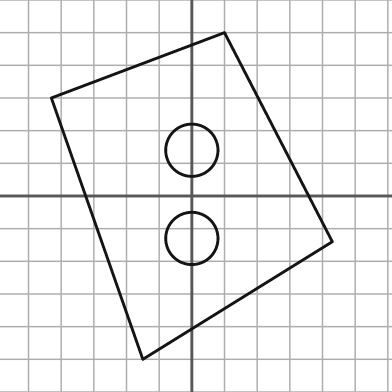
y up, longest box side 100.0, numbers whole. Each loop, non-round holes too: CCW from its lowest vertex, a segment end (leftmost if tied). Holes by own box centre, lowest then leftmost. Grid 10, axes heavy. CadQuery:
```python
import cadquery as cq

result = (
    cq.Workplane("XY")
    .moveTo(-15.0, -50.0)
    .lineTo(43.0, -14.0)
    .lineTo(10.0, 50.0)
    .lineTo(-43.0, 30.0)
    .close()
    .moveTo(0.0, -13.0)
    .circle(8.0)
    .moveTo(0.0, 14.0)
    .circle(8.0)
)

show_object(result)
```